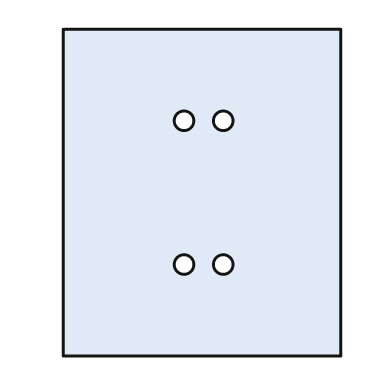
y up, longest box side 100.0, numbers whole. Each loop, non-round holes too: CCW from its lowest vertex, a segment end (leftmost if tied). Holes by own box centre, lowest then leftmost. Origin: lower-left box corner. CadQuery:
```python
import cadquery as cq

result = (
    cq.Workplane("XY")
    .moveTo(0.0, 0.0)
    .lineTo(85.0, 0.0)
    .lineTo(85.0, 100.0)
    .lineTo(0.0, 100.0)
    .close()
    .moveTo(37.0, 28.0)
    .circle(3.0)
    .moveTo(49.0, 28.0)
    .circle(3.0)
    .moveTo(37.0, 72.0)
    .circle(3.0)
    .moveTo(49.0, 72.0)
    .circle(3.0)
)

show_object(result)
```